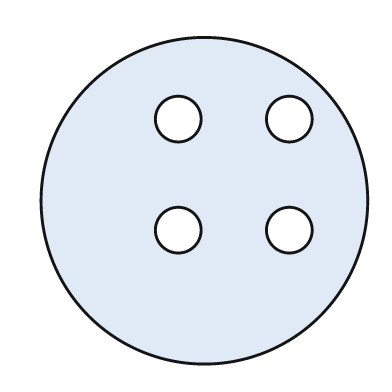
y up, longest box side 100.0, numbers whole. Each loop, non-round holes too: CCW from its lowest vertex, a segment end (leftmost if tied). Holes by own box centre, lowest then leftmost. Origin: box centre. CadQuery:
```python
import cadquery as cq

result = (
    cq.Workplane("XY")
    .moveTo(0.0, 0.0)
    .circle(50.0)
    .moveTo(-8.0, -9.0)
    .circle(7.0)
    .moveTo(26.0, -9.0)
    .circle(7.0)
    .moveTo(-8.0, 25.0)
    .circle(7.0)
    .moveTo(26.0, 25.0)
    .circle(7.0)
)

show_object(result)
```